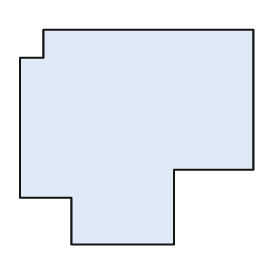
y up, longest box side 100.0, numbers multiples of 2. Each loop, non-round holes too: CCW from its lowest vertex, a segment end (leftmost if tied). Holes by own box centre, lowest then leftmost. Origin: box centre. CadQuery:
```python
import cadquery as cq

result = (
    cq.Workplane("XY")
    .moveTo(-28.0, -46.0)
    .lineTo(16.0, -46.0)
    .lineTo(16.0, -14.0)
    .lineTo(50.0, -14.0)
    .lineTo(50.0, 46.0)
    .lineTo(-40.0, 46.0)
    .lineTo(-40.0, 34.0)
    .lineTo(-50.0, 34.0)
    .lineTo(-50.0, -26.0)
    .lineTo(-28.0, -26.0)
    .close()
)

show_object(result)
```